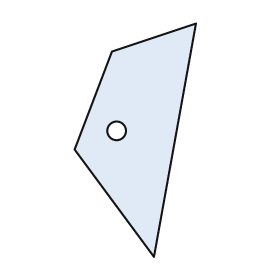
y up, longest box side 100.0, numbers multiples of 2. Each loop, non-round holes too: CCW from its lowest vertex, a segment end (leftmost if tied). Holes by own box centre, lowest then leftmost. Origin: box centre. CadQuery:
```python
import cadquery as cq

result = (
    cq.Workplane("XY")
    .moveTo(8.0, -50.0)
    .lineTo(26.0, 50.0)
    .lineTo(-10.0, 38.0)
    .lineTo(-26.0, -4.0)
    .close()
    .moveTo(-8.0, 4.0)
    .circle(4.0)
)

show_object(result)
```